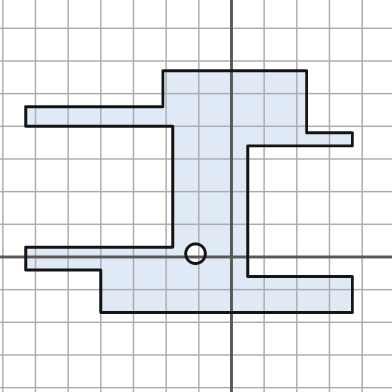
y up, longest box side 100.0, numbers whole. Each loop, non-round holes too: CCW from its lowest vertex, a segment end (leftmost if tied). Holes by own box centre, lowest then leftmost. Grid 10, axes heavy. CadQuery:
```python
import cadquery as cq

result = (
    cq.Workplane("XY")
    .moveTo(-40.0, -17.0)
    .lineTo(37.0, -17.0)
    .lineTo(37.0, -6.0)
    .lineTo(5.0, -6.0)
    .lineTo(5.0, 34.0)
    .lineTo(37.0, 34.0)
    .lineTo(37.0, 38.0)
    .lineTo(23.0, 38.0)
    .lineTo(23.0, 57.0)
    .lineTo(-21.0, 57.0)
    .lineTo(-21.0, 46.0)
    .lineTo(-63.0, 46.0)
    .lineTo(-63.0, 40.0)
    .lineTo(-18.0, 40.0)
    .lineTo(-18.0, 3.0)
    .lineTo(-63.0, 3.0)
    .lineTo(-63.0, -4.0)
    .lineTo(-40.0, -4.0)
    .close()
    .moveTo(-11.0, 1.0)
    .circle(3.0)
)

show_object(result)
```